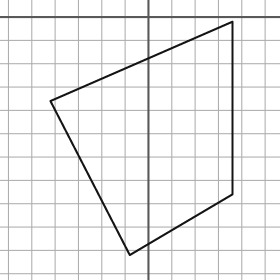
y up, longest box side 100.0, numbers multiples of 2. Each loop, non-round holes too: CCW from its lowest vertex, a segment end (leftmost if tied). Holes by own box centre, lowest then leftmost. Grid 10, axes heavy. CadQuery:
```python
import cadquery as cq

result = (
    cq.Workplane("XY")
    .moveTo(-8.0, -102.0)
    .lineTo(36.0, -76.0)
    .lineTo(36.0, -2.0)
    .lineTo(-42.0, -36.0)
    .close()
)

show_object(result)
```